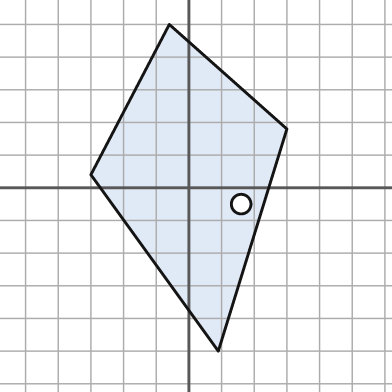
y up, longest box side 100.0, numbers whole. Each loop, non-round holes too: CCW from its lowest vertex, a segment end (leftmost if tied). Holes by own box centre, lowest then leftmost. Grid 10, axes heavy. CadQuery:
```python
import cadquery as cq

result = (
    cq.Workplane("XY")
    .moveTo(9.0, -50.0)
    .lineTo(30.0, 18.0)
    .lineTo(-6.0, 50.0)
    .lineTo(-30.0, 4.0)
    .close()
    .moveTo(16.0, -5.0)
    .circle(3.0)
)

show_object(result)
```